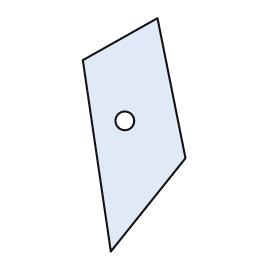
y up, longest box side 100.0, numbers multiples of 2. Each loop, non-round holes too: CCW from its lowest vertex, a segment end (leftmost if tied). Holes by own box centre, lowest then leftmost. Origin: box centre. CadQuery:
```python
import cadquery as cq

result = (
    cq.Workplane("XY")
    .moveTo(-10.0, -50.0)
    .lineTo(22.0, -10.0)
    .lineTo(10.0, 50.0)
    .lineTo(-22.0, 32.0)
    .close()
    .moveTo(-4.0, 6.0)
    .circle(4.0)
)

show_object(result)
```